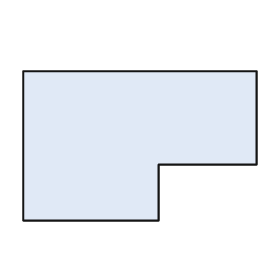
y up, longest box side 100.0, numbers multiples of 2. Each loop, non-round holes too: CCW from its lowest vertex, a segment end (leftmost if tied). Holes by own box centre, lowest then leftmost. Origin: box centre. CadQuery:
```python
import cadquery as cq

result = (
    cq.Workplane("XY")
    .moveTo(-50.0, -32.0)
    .lineTo(8.0, -32.0)
    .lineTo(8.0, -8.0)
    .lineTo(50.0, -8.0)
    .lineTo(50.0, 32.0)
    .lineTo(-50.0, 32.0)
    .close()
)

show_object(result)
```